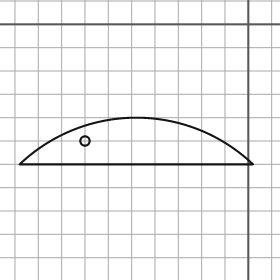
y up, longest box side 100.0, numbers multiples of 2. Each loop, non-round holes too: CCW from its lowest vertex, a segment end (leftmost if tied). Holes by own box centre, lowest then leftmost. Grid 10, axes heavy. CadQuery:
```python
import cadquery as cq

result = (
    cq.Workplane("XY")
    .moveTo(-98.0, -60.0)
    .lineTo(2.0, -60.0)
    .threePointArc((-48.0, -40.0), (-98.0, -60.0))
    .close()
    .moveTo(-70.0, -50.0)
    .circle(2.0)
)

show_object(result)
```